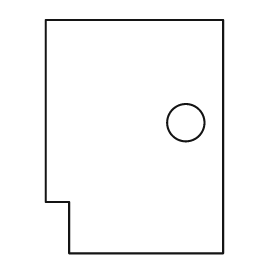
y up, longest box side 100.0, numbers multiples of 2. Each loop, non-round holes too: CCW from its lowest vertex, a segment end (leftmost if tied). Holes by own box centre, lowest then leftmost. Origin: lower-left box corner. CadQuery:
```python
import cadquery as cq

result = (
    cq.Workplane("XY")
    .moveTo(10.0, 0.0)
    .lineTo(76.0, 0.0)
    .lineTo(76.0, 100.0)
    .lineTo(0.0, 100.0)
    .lineTo(0.0, 22.0)
    .lineTo(10.0, 22.0)
    .close()
    .moveTo(60.0, 56.0)
    .circle(8.0)
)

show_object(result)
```